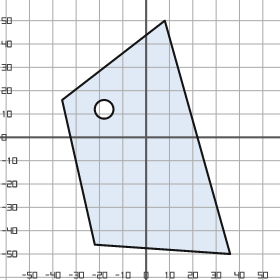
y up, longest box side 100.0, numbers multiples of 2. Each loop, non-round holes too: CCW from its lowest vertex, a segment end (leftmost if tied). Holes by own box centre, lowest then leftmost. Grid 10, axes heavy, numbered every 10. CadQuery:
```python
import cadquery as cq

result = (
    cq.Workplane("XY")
    .moveTo(36.0, -50.0)
    .lineTo(8.0, 50.0)
    .lineTo(-36.0, 16.0)
    .lineTo(-22.0, -46.0)
    .close()
    .moveTo(-18.0, 12.0)
    .circle(4.0)
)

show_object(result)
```